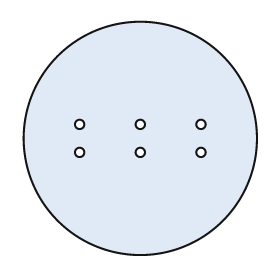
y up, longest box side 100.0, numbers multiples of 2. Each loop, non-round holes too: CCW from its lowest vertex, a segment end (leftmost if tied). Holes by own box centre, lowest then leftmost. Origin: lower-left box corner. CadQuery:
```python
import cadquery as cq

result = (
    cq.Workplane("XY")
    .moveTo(50.0, 50.0)
    .circle(50.0)
    .moveTo(24.0, 44.0)
    .circle(2.0)
    .moveTo(50.0, 44.0)
    .circle(2.0)
    .moveTo(76.0, 44.0)
    .circle(2.0)
    .moveTo(24.0, 56.0)
    .circle(2.0)
    .moveTo(50.0, 56.0)
    .circle(2.0)
    .moveTo(76.0, 56.0)
    .circle(2.0)
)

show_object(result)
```